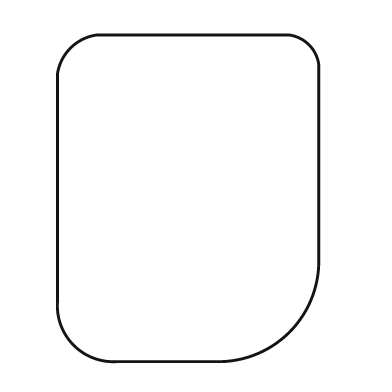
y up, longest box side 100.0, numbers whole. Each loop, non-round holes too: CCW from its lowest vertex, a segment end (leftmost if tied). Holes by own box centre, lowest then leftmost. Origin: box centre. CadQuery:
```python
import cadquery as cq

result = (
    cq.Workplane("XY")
    .moveTo(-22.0, -50.0)
    .lineTo(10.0, -50.0)
    .threePointArc((31.0, -41.0), (40.0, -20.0))
    .lineTo(40.0, 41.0)
    .threePointArc((37.0, 47.0), (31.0, 50.0))
    .lineTo(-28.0, 50.0)
    .threePointArc((-36.0, 46.0), (-40.0, 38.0))
    .lineTo(-40.0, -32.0)
    .threePointArc((-35.0, -45.0), (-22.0, -50.0))
    .close()
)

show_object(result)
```